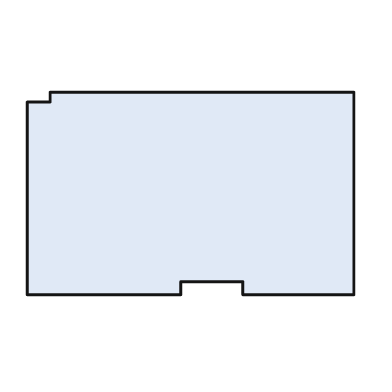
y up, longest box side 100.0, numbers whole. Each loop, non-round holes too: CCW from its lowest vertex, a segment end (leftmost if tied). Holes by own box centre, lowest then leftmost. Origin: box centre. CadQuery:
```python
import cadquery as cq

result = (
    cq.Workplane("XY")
    .moveTo(-50.0, -31.0)
    .lineTo(-3.0, -31.0)
    .lineTo(-3.0, -27.0)
    .lineTo(16.0, -27.0)
    .lineTo(16.0, -31.0)
    .lineTo(50.0, -31.0)
    .lineTo(50.0, 31.0)
    .lineTo(-43.0, 31.0)
    .lineTo(-43.0, 28.0)
    .lineTo(-50.0, 28.0)
    .close()
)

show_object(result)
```